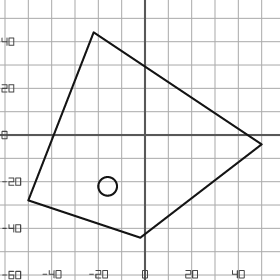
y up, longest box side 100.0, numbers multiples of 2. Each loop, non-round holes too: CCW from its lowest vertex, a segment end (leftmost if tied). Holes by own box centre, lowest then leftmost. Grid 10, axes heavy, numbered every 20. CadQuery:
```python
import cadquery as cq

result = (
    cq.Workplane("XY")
    .moveTo(-2.0, -44.0)
    .lineTo(50.0, -4.0)
    .lineTo(-22.0, 44.0)
    .lineTo(-50.0, -28.0)
    .close()
    .moveTo(-16.0, -22.0)
    .circle(4.0)
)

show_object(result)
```